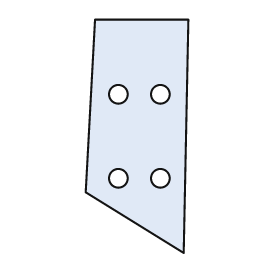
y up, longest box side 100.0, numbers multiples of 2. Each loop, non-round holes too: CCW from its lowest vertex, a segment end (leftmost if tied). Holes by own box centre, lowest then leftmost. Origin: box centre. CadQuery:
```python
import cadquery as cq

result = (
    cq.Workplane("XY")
    .moveTo(20.0, -50.0)
    .lineTo(22.0, 50.0)
    .lineTo(-18.0, 50.0)
    .lineTo(-22.0, -24.0)
    .close()
    .moveTo(-8.0, -18.0)
    .circle(4.0)
    .moveTo(10.0, -18.0)
    .circle(4.0)
    .moveTo(-8.0, 18.0)
    .circle(4.0)
    .moveTo(10.0, 18.0)
    .circle(4.0)
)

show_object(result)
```